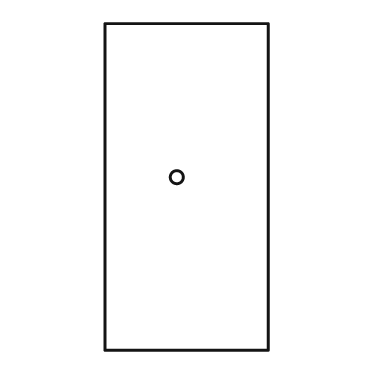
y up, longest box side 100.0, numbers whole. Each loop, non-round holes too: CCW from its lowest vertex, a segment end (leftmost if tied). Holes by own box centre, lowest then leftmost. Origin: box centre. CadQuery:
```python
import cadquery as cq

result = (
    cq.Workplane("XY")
    .moveTo(-25.0, -50.0)
    .lineTo(25.0, -50.0)
    .lineTo(25.0, 50.0)
    .lineTo(-25.0, 50.0)
    .close()
    .moveTo(-3.0, 3.0)
    .circle(2.0)
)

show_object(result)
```